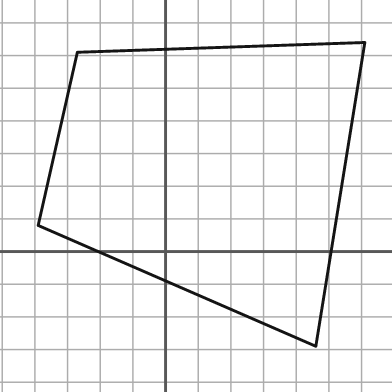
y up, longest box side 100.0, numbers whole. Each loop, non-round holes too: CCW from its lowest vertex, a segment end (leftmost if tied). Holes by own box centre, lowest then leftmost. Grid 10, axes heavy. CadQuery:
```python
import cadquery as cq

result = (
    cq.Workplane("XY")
    .moveTo(46.0, -29.0)
    .lineTo(61.0, 64.0)
    .lineTo(-27.0, 61.0)
    .lineTo(-39.0, 8.0)
    .close()
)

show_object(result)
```